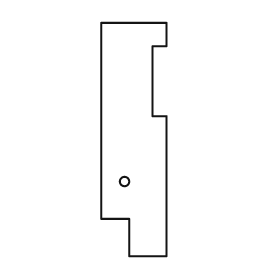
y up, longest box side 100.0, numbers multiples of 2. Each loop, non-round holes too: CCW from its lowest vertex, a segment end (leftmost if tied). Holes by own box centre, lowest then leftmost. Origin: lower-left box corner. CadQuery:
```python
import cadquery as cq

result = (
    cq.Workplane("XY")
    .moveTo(12.0, 0.0)
    .lineTo(28.0, 0.0)
    .lineTo(28.0, 60.0)
    .lineTo(22.0, 60.0)
    .lineTo(22.0, 90.0)
    .lineTo(28.0, 90.0)
    .lineTo(28.0, 100.0)
    .lineTo(0.0, 100.0)
    .lineTo(0.0, 16.0)
    .lineTo(12.0, 16.0)
    .close()
    .moveTo(10.0, 32.0)
    .circle(2.0)
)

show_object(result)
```